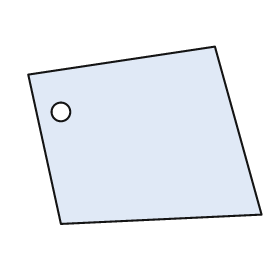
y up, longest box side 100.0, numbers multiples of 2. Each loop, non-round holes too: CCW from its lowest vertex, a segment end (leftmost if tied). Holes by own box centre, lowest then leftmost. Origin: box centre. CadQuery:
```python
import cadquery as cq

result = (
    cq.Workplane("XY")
    .moveTo(-36.0, -38.0)
    .lineTo(50.0, -34.0)
    .lineTo(30.0, 38.0)
    .lineTo(-50.0, 26.0)
    .close()
    .moveTo(-36.0, 10.0)
    .circle(4.0)
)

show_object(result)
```